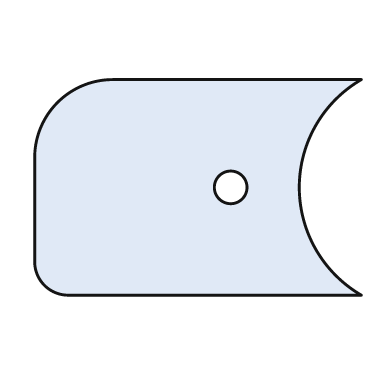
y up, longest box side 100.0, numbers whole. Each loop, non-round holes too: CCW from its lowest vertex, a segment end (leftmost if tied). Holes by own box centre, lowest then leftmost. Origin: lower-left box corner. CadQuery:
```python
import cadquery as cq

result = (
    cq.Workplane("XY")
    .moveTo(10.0, 0.0)
    .lineTo(100.0, 0.0)
    .threePointArc((81.0, 33.0), (100.0, 66.0))
    .lineTo(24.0, 66.0)
    .threePointArc((7.0, 59.0), (0.0, 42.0))
    .lineTo(0.0, 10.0)
    .threePointArc((3.0, 3.0), (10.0, 0.0))
    .close()
    .moveTo(60.0, 33.0)
    .circle(5.0)
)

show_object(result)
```